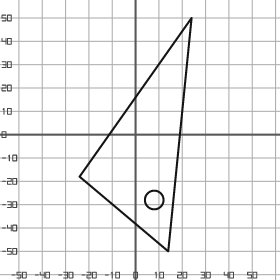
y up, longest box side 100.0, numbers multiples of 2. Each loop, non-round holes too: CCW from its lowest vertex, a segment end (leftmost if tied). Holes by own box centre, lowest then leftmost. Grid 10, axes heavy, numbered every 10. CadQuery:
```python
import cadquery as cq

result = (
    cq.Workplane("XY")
    .moveTo(14.0, -50.0)
    .lineTo(24.0, 50.0)
    .lineTo(-24.0, -18.0)
    .close()
    .moveTo(8.0, -28.0)
    .circle(4.0)
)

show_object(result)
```